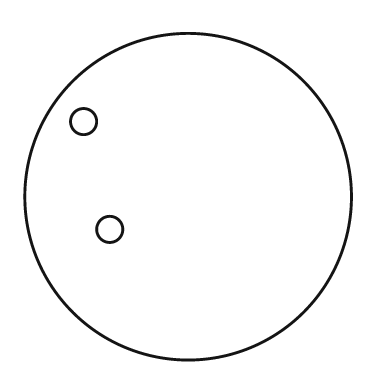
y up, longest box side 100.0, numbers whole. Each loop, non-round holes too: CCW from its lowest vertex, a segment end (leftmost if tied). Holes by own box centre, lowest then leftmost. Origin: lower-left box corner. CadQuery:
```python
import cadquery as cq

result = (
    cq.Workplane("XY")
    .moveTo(50.0, 50.0)
    .circle(50.0)
    .moveTo(26.0, 40.0)
    .circle(4.0)
    .moveTo(18.0, 73.0)
    .circle(4.0)
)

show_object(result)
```